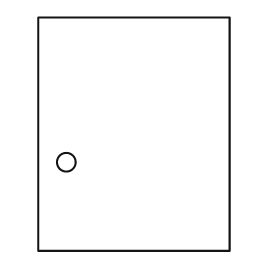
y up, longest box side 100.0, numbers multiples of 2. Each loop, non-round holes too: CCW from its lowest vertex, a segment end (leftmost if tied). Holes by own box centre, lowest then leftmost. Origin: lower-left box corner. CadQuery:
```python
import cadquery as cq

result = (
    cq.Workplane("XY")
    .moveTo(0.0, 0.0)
    .lineTo(82.0, 0.0)
    .lineTo(82.0, 100.0)
    .lineTo(0.0, 100.0)
    .close()
    .moveTo(12.0, 38.0)
    .circle(4.0)
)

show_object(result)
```